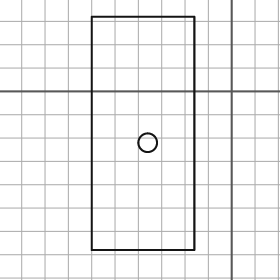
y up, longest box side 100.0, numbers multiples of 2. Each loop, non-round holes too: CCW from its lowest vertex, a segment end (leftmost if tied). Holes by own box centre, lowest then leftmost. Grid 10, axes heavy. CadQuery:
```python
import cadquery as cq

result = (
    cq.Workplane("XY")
    .moveTo(-60.0, -68.0)
    .lineTo(-16.0, -68.0)
    .lineTo(-16.0, 32.0)
    .lineTo(-60.0, 32.0)
    .close()
    .moveTo(-36.0, -22.0)
    .circle(4.0)
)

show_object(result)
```